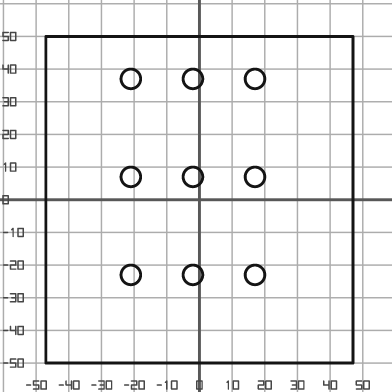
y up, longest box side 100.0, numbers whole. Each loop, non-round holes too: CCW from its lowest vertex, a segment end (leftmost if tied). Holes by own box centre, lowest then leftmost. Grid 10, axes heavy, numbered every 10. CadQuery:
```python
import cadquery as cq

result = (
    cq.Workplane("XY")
    .moveTo(-47.0, -50.0)
    .lineTo(47.0, -50.0)
    .lineTo(47.0, 50.0)
    .lineTo(-47.0, 50.0)
    .close()
    .moveTo(-21.0, -23.0)
    .circle(3.0)
    .moveTo(-2.0, -23.0)
    .circle(3.0)
    .moveTo(17.0, -23.0)
    .circle(3.0)
    .moveTo(-21.0, 7.0)
    .circle(3.0)
    .moveTo(-2.0, 7.0)
    .circle(3.0)
    .moveTo(17.0, 7.0)
    .circle(3.0)
    .moveTo(-21.0, 37.0)
    .circle(3.0)
    .moveTo(-2.0, 37.0)
    .circle(3.0)
    .moveTo(17.0, 37.0)
    .circle(3.0)
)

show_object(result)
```